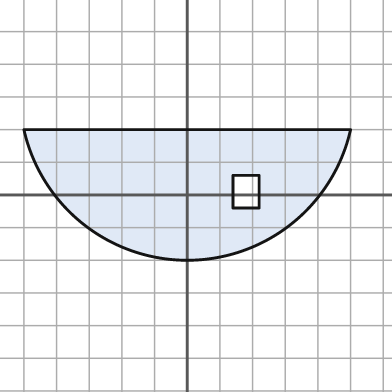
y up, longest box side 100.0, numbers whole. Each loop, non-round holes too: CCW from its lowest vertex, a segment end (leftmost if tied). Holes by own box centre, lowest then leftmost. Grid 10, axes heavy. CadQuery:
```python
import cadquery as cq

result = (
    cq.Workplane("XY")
    .moveTo(-50.0, 20.0)
    .threePointArc((0.0, -20.0), (50.0, 20.0))
    .close()
    .moveTo(14.0, -4.0)
    .lineTo(22.0, -4.0)
    .lineTo(22.0, 6.0)
    .lineTo(14.0, 6.0)
    .close()
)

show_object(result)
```